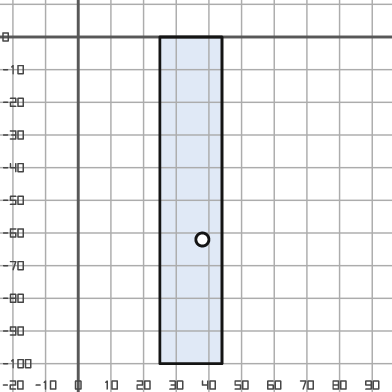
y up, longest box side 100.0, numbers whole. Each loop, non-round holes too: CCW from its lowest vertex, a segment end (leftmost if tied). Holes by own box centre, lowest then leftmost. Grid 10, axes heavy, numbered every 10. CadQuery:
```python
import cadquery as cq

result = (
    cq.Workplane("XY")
    .moveTo(25.0, -100.0)
    .lineTo(44.0, -100.0)
    .lineTo(44.0, 0.0)
    .lineTo(25.0, 0.0)
    .close()
    .moveTo(38.0, -62.0)
    .circle(2.0)
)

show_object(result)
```